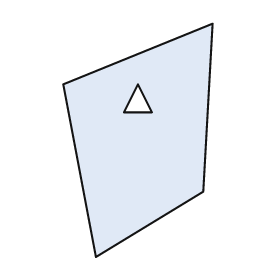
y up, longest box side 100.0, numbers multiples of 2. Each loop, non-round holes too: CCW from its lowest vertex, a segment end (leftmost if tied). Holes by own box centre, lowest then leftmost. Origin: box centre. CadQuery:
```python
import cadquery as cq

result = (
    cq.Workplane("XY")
    .moveTo(-18.0, -50.0)
    .lineTo(28.0, -22.0)
    .lineTo(32.0, 50.0)
    .lineTo(-32.0, 24.0)
    .close()
    .moveTo(-6.0, 12.0)
    .lineTo(6.0, 12.0)
    .lineTo(0.0, 24.0)
    .close()
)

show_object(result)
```